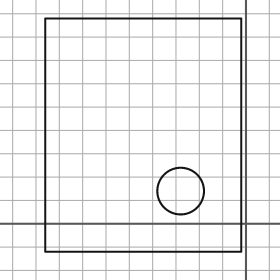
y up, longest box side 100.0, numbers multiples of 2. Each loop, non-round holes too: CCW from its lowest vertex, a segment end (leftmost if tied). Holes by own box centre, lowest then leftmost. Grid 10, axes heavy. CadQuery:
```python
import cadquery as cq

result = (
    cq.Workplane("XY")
    .moveTo(-86.0, -12.0)
    .lineTo(-2.0, -12.0)
    .lineTo(-2.0, 88.0)
    .lineTo(-86.0, 88.0)
    .close()
    .moveTo(-28.0, 14.0)
    .circle(10.0)
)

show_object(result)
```